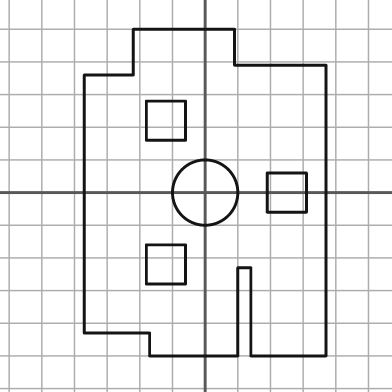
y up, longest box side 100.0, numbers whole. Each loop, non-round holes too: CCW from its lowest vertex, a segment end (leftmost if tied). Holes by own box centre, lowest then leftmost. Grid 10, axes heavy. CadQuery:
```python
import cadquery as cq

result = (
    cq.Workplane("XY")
    .moveTo(-17.0, -50.0)
    .lineTo(10.0, -50.0)
    .lineTo(10.0, -23.0)
    .lineTo(14.0, -23.0)
    .lineTo(14.0, -50.0)
    .lineTo(37.0, -50.0)
    .lineTo(37.0, 39.0)
    .lineTo(9.0, 39.0)
    .lineTo(9.0, 50.0)
    .lineTo(-22.0, 50.0)
    .lineTo(-22.0, 36.0)
    .lineTo(-37.0, 36.0)
    .lineTo(-37.0, -43.0)
    .lineTo(-17.0, -43.0)
    .close()
    .moveTo(-18.0, -28.0)
    .lineTo(-6.0, -28.0)
    .lineTo(-6.0, -16.0)
    .lineTo(-18.0, -16.0)
    .close()
    .moveTo(0.0, 0.0)
    .circle(10.0)
    .moveTo(19.0, -6.0)
    .lineTo(31.0, -6.0)
    .lineTo(31.0, 6.0)
    .lineTo(19.0, 6.0)
    .close()
    .moveTo(-18.0, 16.0)
    .lineTo(-6.0, 16.0)
    .lineTo(-6.0, 28.0)
    .lineTo(-18.0, 28.0)
    .close()
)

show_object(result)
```